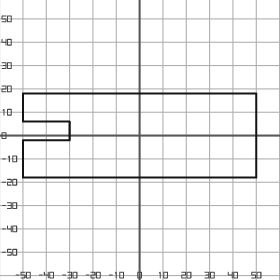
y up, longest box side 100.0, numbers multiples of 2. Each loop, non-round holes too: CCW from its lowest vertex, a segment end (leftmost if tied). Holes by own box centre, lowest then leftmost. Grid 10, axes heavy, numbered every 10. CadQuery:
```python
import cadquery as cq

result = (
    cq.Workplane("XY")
    .moveTo(-50.0, -18.0)
    .lineTo(50.0, -18.0)
    .lineTo(50.0, 18.0)
    .lineTo(-50.0, 18.0)
    .lineTo(-50.0, 6.0)
    .lineTo(-30.0, 6.0)
    .lineTo(-30.0, -2.0)
    .lineTo(-50.0, -2.0)
    .close()
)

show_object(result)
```